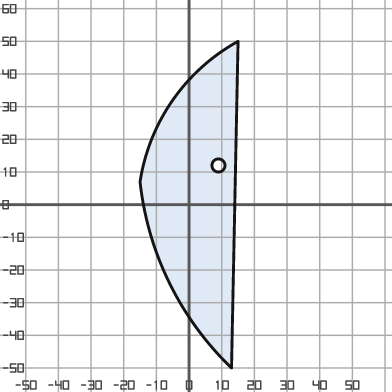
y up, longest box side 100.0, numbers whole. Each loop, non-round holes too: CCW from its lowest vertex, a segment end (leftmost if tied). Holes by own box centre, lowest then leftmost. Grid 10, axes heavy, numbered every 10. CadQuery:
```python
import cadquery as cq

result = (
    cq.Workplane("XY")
    .moveTo(13.0, -50.0)
    .lineTo(15.0, 50.0)
    .threePointArc((-5.0, 32.0), (-15.0, 7.0))
    .threePointArc((-6.0, -24.0), (13.0, -50.0))
    .close()
    .moveTo(9.0, 12.0)
    .circle(2.0)
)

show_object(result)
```